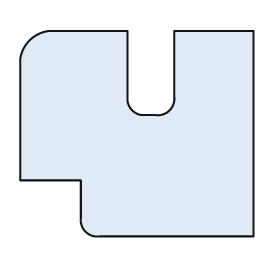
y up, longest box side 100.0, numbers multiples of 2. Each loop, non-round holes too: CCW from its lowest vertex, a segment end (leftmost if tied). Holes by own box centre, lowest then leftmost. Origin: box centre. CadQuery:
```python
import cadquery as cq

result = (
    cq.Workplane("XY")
    .moveTo(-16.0, -44.0)
    .lineTo(50.0, -44.0)
    .lineTo(50.0, 44.0)
    .lineTo(16.0, 44.0)
    .lineTo(16.0, 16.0)
    .threePointArc((14.0, 10.0), (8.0, 8.0))
    .lineTo(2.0, 8.0)
    .threePointArc((-2.0, 10.0), (-4.0, 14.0))
    .lineTo(-4.0, 44.0)
    .lineTo(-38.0, 44.0)
    .threePointArc((-46.0, 40.0), (-50.0, 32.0))
    .lineTo(-50.0, -20.0)
    .lineTo(-24.0, -20.0)
    .lineTo(-24.0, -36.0)
    .threePointArc((-22.0, -42.0), (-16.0, -44.0))
    .close()
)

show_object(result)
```